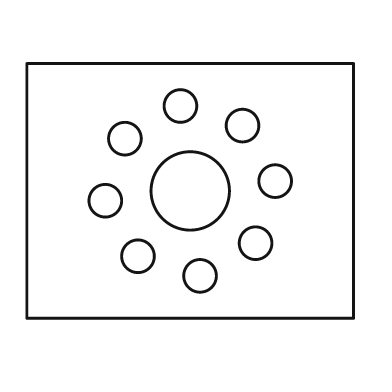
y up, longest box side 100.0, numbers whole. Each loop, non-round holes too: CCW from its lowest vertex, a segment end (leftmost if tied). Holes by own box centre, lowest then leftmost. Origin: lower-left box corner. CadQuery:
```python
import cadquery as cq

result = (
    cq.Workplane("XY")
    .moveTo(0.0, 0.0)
    .lineTo(100.0, 0.0)
    .lineTo(100.0, 78.0)
    .lineTo(0.0, 78.0)
    .close()
    .moveTo(53.0, 13.0)
    .circle(5.0)
    .moveTo(34.0, 19.0)
    .circle(5.0)
    .moveTo(70.0, 23.0)
    .circle(5.0)
    .moveTo(24.0, 36.0)
    .circle(5.0)
    .moveTo(50.0, 39.0)
    .circle(12.0)
    .moveTo(76.0, 42.0)
    .circle(5.0)
    .moveTo(30.0, 55.0)
    .circle(5.0)
    .moveTo(66.0, 59.0)
    .circle(5.0)
    .moveTo(47.0, 65.0)
    .circle(5.0)
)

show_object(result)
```